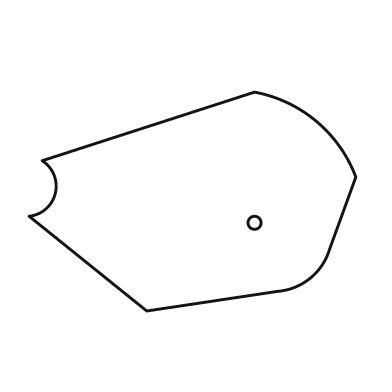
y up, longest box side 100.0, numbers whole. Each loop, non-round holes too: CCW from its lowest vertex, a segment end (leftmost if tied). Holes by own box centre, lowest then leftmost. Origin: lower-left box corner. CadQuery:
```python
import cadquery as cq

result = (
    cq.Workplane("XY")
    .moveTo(36.0, 0.0)
    .lineTo(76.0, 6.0)
    .threePointArc((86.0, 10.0), (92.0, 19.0))
    .lineTo(100.0, 41.0)
    .threePointArc((88.0, 58.0), (69.0, 67.0))
    .lineTo(4.0, 46.0)
    .threePointArc((8.0, 36.0), (0.0, 29.0))
    .close()
    .moveTo(69.0, 27.0)
    .circle(2.0)
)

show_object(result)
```